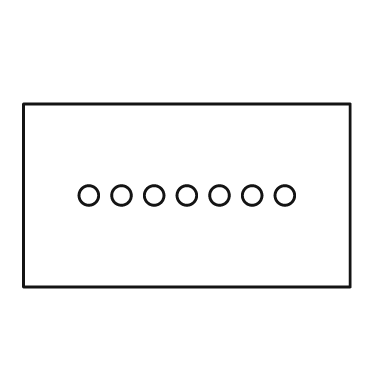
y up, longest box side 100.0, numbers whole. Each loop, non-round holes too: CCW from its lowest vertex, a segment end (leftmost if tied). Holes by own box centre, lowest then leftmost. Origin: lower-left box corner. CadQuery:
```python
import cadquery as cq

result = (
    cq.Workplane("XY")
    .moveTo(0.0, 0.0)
    .lineTo(100.0, 0.0)
    .lineTo(100.0, 56.0)
    .lineTo(0.0, 56.0)
    .close()
    .moveTo(20.0, 28.0)
    .circle(3.0)
    .moveTo(30.0, 28.0)
    .circle(3.0)
    .moveTo(40.0, 28.0)
    .circle(3.0)
    .moveTo(50.0, 28.0)
    .circle(3.0)
    .moveTo(60.0, 28.0)
    .circle(3.0)
    .moveTo(70.0, 28.0)
    .circle(3.0)
    .moveTo(80.0, 28.0)
    .circle(3.0)
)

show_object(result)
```